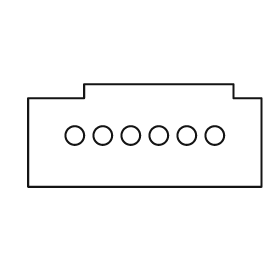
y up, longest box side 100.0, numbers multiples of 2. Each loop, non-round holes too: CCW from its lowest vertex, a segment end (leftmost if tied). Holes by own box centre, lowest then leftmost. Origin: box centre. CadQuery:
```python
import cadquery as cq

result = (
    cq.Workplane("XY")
    .moveTo(-50.0, -22.0)
    .lineTo(50.0, -22.0)
    .lineTo(50.0, 16.0)
    .lineTo(38.0, 16.0)
    .lineTo(38.0, 22.0)
    .lineTo(-26.0, 22.0)
    .lineTo(-26.0, 16.0)
    .lineTo(-50.0, 16.0)
    .close()
    .moveTo(-30.0, 0.0)
    .circle(4.0)
    .moveTo(-18.0, 0.0)
    .circle(4.0)
    .moveTo(-6.0, 0.0)
    .circle(4.0)
    .moveTo(6.0, 0.0)
    .circle(4.0)
    .moveTo(18.0, 0.0)
    .circle(4.0)
    .moveTo(30.0, 0.0)
    .circle(4.0)
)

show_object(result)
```